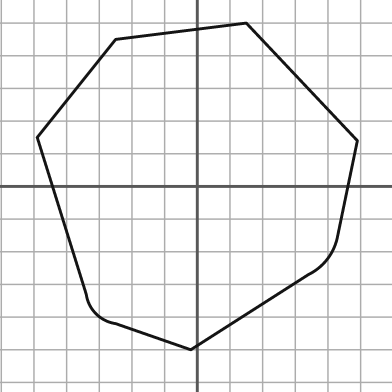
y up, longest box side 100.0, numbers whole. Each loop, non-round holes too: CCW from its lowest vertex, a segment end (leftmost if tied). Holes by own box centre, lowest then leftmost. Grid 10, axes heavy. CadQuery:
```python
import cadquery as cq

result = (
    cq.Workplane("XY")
    .moveTo(-2.0, -50.0)
    .lineTo(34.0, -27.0)
    .threePointArc((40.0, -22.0), (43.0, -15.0))
    .lineTo(49.0, 14.0)
    .lineTo(15.0, 50.0)
    .lineTo(-25.0, 45.0)
    .lineTo(-49.0, 15.0)
    .lineTo(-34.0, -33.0)
    .threePointArc((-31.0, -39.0), (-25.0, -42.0))
    .close()
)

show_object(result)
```